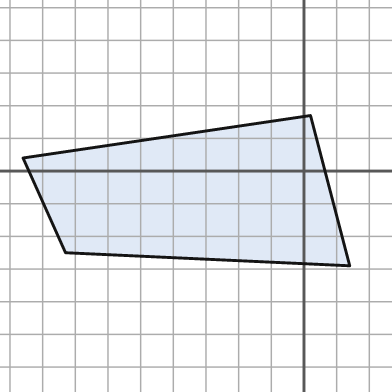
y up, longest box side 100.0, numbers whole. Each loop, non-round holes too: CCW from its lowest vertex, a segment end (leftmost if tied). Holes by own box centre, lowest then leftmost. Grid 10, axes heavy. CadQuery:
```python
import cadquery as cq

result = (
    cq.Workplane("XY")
    .moveTo(14.0, -29.0)
    .lineTo(2.0, 17.0)
    .lineTo(-86.0, 4.0)
    .lineTo(-73.0, -25.0)
    .close()
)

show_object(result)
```